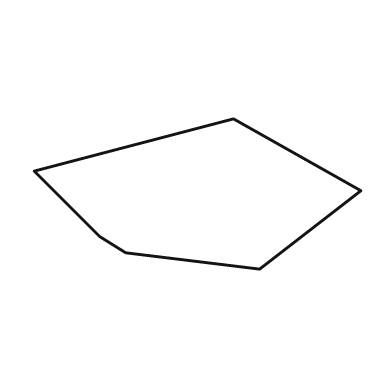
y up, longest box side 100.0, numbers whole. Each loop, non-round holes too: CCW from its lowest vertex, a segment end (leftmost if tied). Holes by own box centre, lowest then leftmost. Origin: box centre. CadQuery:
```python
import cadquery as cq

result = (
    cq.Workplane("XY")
    .moveTo(19.0, -23.0)
    .lineTo(50.0, 1.0)
    .lineTo(11.0, 23.0)
    .lineTo(-50.0, 7.0)
    .lineTo(-30.0, -13.0)
    .lineTo(-22.0, -18.0)
    .close()
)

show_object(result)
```